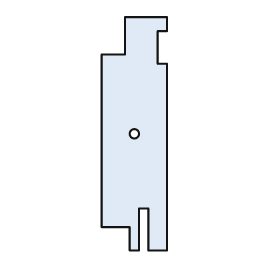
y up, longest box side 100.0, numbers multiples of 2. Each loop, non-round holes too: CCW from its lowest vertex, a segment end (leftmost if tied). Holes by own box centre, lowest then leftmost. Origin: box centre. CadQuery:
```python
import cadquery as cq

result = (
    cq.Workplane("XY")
    .moveTo(-2.0, -50.0)
    .lineTo(2.0, -50.0)
    .lineTo(2.0, -32.0)
    .lineTo(6.0, -32.0)
    .lineTo(6.0, -50.0)
    .lineTo(14.0, -50.0)
    .lineTo(14.0, 30.0)
    .lineTo(10.0, 30.0)
    .lineTo(10.0, 44.0)
    .lineTo(14.0, 44.0)
    .lineTo(14.0, 50.0)
    .lineTo(-4.0, 50.0)
    .lineTo(-4.0, 34.0)
    .lineTo(-14.0, 34.0)
    .lineTo(-14.0, -40.0)
    .lineTo(-2.0, -40.0)
    .close()
    .moveTo(0.0, 0.0)
    .circle(2.0)
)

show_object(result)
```